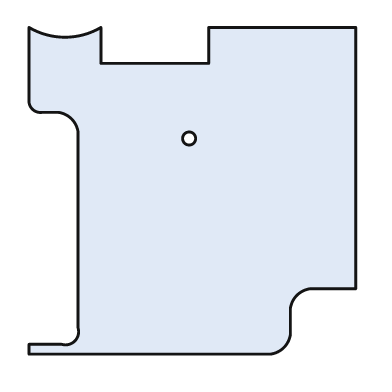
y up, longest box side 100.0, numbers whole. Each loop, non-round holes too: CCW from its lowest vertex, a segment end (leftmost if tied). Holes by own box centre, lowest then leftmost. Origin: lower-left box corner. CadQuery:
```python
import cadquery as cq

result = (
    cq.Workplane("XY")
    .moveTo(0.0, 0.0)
    .lineTo(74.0, 0.0)
    .threePointArc((78.0, 2.0), (80.0, 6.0))
    .lineTo(80.0, 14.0)
    .threePointArc((82.0, 18.0), (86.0, 20.0))
    .lineTo(100.0, 20.0)
    .lineTo(100.0, 100.0)
    .lineTo(55.0, 100.0)
    .lineTo(55.0, 89.0)
    .lineTo(22.0, 89.0)
    .lineTo(22.0, 100.0)
    .threePointArc((11.0, 97.0), (0.0, 100.0))
    .lineTo(0.0, 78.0)
    .threePointArc((1.0, 75.0), (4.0, 74.0))
    .lineTo(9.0, 74.0)
    .threePointArc((13.0, 72.0), (15.0, 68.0))
    .lineTo(15.0, 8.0)
    .threePointArc((14.0, 4.0), (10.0, 3.0))
    .lineTo(0.0, 3.0)
    .close()
    .moveTo(49.0, 66.0)
    .circle(2.0)
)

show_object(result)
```